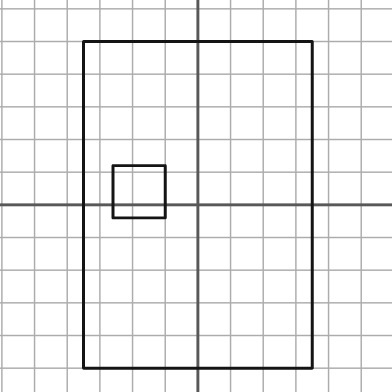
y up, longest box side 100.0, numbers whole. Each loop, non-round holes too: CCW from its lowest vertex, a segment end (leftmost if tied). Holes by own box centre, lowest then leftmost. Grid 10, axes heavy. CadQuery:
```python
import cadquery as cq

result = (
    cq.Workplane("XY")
    .moveTo(-35.0, -50.0)
    .lineTo(35.0, -50.0)
    .lineTo(35.0, 50.0)
    .lineTo(-35.0, 50.0)
    .close()
    .moveTo(-26.0, -4.0)
    .lineTo(-10.0, -4.0)
    .lineTo(-10.0, 12.0)
    .lineTo(-26.0, 12.0)
    .close()
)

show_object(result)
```